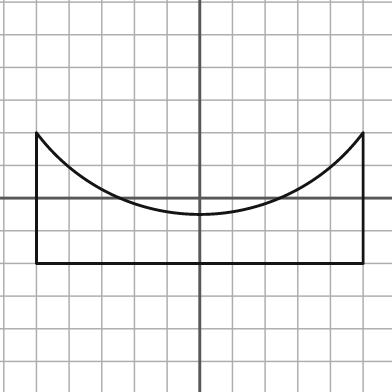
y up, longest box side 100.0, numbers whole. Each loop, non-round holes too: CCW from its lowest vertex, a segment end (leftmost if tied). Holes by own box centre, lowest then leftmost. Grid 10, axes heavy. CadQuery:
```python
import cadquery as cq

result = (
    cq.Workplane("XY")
    .moveTo(-50.0, -20.0)
    .lineTo(50.0, -20.0)
    .lineTo(50.0, 20.0)
    .threePointArc((0.0, -5.0), (-50.0, 20.0))
    .close()
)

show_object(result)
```